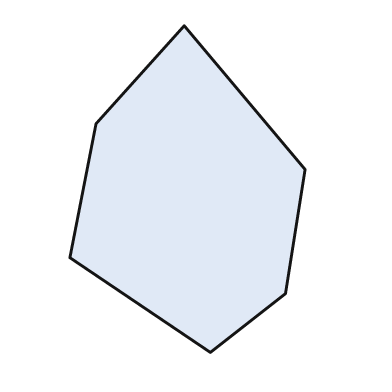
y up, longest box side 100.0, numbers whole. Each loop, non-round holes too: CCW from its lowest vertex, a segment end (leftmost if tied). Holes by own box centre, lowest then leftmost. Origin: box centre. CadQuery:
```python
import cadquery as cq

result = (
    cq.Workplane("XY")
    .moveTo(7.0, -50.0)
    .lineTo(30.0, -32.0)
    .lineTo(36.0, 6.0)
    .lineTo(-1.0, 50.0)
    .lineTo(-28.0, 20.0)
    .lineTo(-36.0, -21.0)
    .close()
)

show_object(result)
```